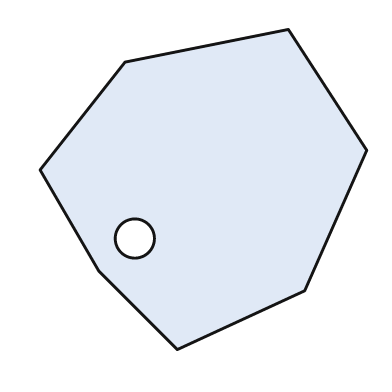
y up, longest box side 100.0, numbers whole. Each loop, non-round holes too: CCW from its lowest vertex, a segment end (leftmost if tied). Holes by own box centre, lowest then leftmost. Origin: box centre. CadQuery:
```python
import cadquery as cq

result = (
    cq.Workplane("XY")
    .moveTo(-8.0, -49.0)
    .lineTo(31.0, -31.0)
    .lineTo(50.0, 12.0)
    .lineTo(26.0, 49.0)
    .lineTo(-24.0, 39.0)
    .lineTo(-50.0, 6.0)
    .lineTo(-32.0, -25.0)
    .close()
    .moveTo(-21.0, -15.0)
    .circle(6.0)
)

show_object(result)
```